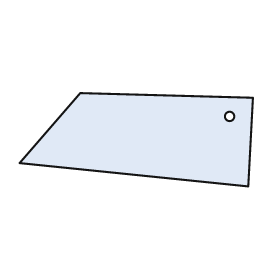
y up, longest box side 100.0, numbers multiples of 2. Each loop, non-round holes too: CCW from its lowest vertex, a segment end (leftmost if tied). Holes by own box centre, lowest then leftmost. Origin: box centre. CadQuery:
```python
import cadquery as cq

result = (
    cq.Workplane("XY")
    .moveTo(48.0, -20.0)
    .lineTo(50.0, 18.0)
    .lineTo(-24.0, 20.0)
    .lineTo(-50.0, -10.0)
    .close()
    .moveTo(40.0, 10.0)
    .circle(2.0)
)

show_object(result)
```